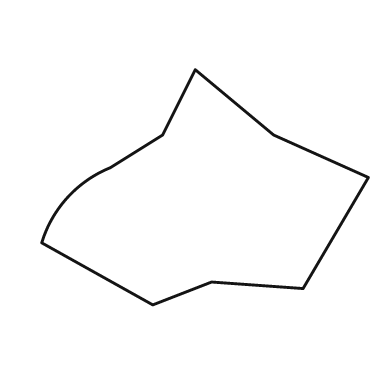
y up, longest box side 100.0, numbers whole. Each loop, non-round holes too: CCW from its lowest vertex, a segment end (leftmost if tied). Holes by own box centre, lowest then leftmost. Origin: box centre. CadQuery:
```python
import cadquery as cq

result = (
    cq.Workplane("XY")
    .moveTo(-16.0, -36.0)
    .lineTo(2.0, -29.0)
    .lineTo(30.0, -31.0)
    .lineTo(50.0, 3.0)
    .lineTo(21.0, 16.0)
    .lineTo(-3.0, 36.0)
    .lineTo(-13.0, 16.0)
    .lineTo(-29.0, 6.0)
    .threePointArc((-42.0, -3.0), (-50.0, -17.0))
    .close()
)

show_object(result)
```